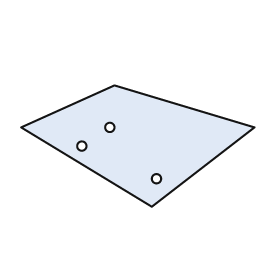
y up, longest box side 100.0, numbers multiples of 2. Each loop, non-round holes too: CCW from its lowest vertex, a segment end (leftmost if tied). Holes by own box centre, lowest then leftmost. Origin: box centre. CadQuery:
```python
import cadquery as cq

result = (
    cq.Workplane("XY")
    .moveTo(6.0, -26.0)
    .lineTo(50.0, 8.0)
    .lineTo(-10.0, 26.0)
    .lineTo(-50.0, 8.0)
    .close()
    .moveTo(8.0, -14.0)
    .circle(2.0)
    .moveTo(-24.0, 0.0)
    .circle(2.0)
    .moveTo(-12.0, 8.0)
    .circle(2.0)
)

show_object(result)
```